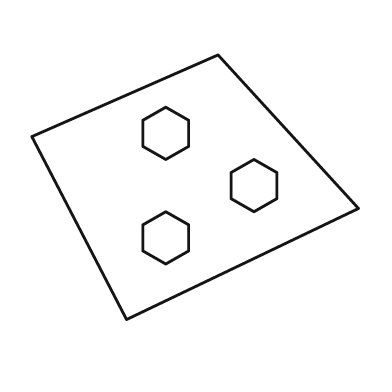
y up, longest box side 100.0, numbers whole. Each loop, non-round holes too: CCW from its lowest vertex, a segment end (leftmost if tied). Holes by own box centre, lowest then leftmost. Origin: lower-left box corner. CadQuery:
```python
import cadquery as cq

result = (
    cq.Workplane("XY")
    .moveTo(29.0, 0.0)
    .lineTo(100.0, 34.0)
    .lineTo(57.0, 81.0)
    .lineTo(0.0, 56.0)
    .close()
    .moveTo(41.0, 17.0)
    .lineTo(48.0, 21.0)
    .lineTo(48.0, 29.0)
    .lineTo(41.0, 33.0)
    .lineTo(34.0, 29.0)
    .lineTo(34.0, 21.0)
    .close()
    .moveTo(68.0, 33.0)
    .lineTo(75.0, 37.0)
    .lineTo(75.0, 45.0)
    .lineTo(68.0, 49.0)
    .lineTo(61.0, 45.0)
    .lineTo(61.0, 37.0)
    .close()
    .moveTo(41.0, 49.0)
    .lineTo(48.0, 53.0)
    .lineTo(48.0, 61.0)
    .lineTo(41.0, 65.0)
    .lineTo(34.0, 61.0)
    .lineTo(34.0, 53.0)
    .close()
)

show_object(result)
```